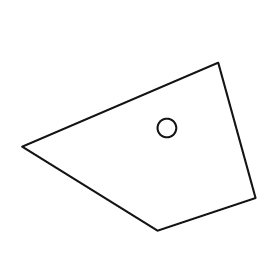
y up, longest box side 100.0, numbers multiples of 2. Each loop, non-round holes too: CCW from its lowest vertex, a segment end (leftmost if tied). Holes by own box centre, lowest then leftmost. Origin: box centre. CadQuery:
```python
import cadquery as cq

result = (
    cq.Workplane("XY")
    .moveTo(8.0, -36.0)
    .lineTo(50.0, -22.0)
    .lineTo(34.0, 36.0)
    .lineTo(-50.0, 0.0)
    .close()
    .moveTo(12.0, 8.0)
    .circle(4.0)
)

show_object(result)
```